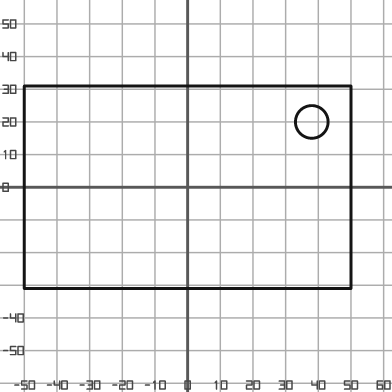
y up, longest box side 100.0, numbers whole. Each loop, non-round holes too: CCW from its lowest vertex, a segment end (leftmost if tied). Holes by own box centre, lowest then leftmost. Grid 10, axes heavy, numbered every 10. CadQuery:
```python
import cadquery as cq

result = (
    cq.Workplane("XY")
    .moveTo(-50.0, -31.0)
    .lineTo(50.0, -31.0)
    .lineTo(50.0, 31.0)
    .lineTo(-50.0, 31.0)
    .close()
    .moveTo(38.0, 20.0)
    .circle(5.0)
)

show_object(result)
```